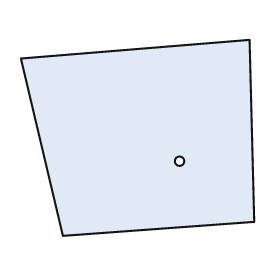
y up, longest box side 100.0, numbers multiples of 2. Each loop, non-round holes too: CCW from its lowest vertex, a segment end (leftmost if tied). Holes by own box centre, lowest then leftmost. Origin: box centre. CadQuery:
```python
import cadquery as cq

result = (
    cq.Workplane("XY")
    .moveTo(-32.0, -42.0)
    .lineTo(50.0, -36.0)
    .lineTo(48.0, 42.0)
    .lineTo(-50.0, 34.0)
    .close()
    .moveTo(18.0, -10.0)
    .circle(2.0)
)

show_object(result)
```